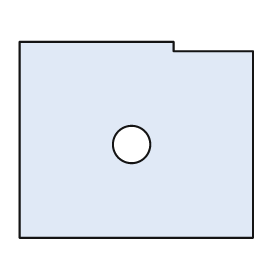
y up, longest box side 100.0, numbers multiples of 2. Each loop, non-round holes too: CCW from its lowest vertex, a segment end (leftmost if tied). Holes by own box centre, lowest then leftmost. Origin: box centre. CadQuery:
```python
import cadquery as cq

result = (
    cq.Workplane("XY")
    .moveTo(-50.0, -42.0)
    .lineTo(50.0, -42.0)
    .lineTo(50.0, 38.0)
    .lineTo(16.0, 38.0)
    .lineTo(16.0, 42.0)
    .lineTo(-50.0, 42.0)
    .close()
    .moveTo(-2.0, -2.0)
    .circle(8.0)
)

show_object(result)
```